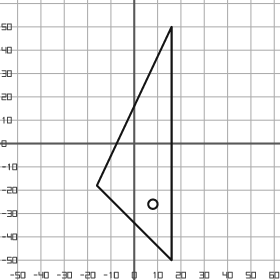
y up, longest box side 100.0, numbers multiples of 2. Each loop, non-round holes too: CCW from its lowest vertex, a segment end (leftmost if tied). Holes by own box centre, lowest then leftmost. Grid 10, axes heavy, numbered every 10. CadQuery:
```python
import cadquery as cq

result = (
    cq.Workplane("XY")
    .moveTo(16.0, -50.0)
    .lineTo(16.0, 50.0)
    .lineTo(-16.0, -18.0)
    .close()
    .moveTo(8.0, -26.0)
    .circle(2.0)
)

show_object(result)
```